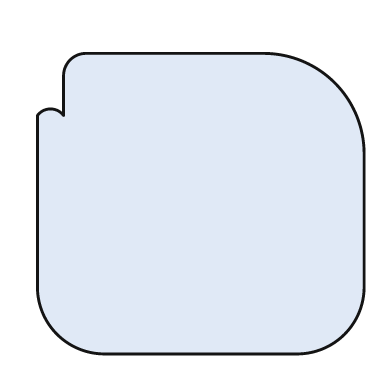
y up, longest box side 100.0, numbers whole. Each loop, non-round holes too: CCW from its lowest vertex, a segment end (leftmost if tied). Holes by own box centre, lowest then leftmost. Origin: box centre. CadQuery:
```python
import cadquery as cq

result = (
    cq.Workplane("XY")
    .moveTo(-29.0, -46.0)
    .lineTo(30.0, -46.0)
    .threePointArc((44.0, -40.0), (50.0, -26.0))
    .lineTo(50.0, 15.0)
    .threePointArc((41.0, 37.0), (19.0, 46.0))
    .lineTo(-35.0, 46.0)
    .threePointArc((-40.0, 44.0), (-42.0, 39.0))
    .lineTo(-42.0, 27.0)
    .threePointArc((-46.0, 29.0), (-50.0, 27.0))
    .lineTo(-50.0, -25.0)
    .threePointArc((-44.0, -40.0), (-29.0, -46.0))
    .close()
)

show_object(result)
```